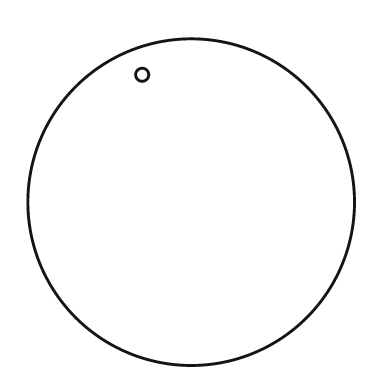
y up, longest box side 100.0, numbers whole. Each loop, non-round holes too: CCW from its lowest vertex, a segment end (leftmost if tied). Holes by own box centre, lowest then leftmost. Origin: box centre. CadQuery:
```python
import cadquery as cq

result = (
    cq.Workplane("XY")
    .moveTo(0.0, 0.0)
    .circle(50.0)
    .moveTo(-15.0, 39.0)
    .circle(2.0)
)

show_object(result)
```